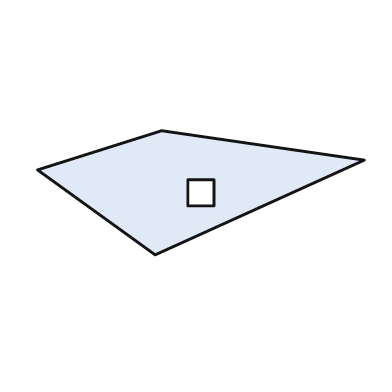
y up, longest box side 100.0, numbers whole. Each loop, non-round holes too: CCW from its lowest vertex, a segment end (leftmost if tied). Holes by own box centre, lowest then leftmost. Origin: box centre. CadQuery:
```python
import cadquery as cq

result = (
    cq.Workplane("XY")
    .moveTo(-14.0, -19.0)
    .lineTo(50.0, 10.0)
    .lineTo(-12.0, 19.0)
    .lineTo(-50.0, 7.0)
    .close()
    .moveTo(-4.0, -4.0)
    .lineTo(4.0, -4.0)
    .lineTo(4.0, 4.0)
    .lineTo(-4.0, 4.0)
    .close()
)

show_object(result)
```